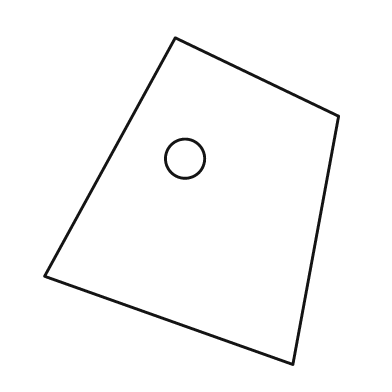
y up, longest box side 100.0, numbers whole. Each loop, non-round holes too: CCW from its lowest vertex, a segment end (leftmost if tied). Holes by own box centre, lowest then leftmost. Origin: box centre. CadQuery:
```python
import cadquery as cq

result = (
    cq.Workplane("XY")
    .moveTo(31.0, -50.0)
    .lineTo(45.0, 26.0)
    .lineTo(-5.0, 50.0)
    .lineTo(-45.0, -23.0)
    .close()
    .moveTo(-2.0, 13.0)
    .circle(6.0)
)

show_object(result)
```